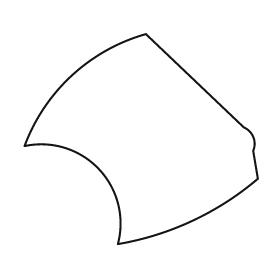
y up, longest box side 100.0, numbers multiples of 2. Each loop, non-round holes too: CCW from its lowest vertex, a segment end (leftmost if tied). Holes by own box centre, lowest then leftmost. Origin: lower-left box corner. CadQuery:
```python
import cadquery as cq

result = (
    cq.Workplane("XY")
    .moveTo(40.0, 0.0)
    .threePointArc((72.0, 10.0), (100.0, 28.0))
    .lineTo(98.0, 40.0)
    .threePointArc((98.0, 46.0), (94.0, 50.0))
    .lineTo(52.0, 90.0)
    .threePointArc((20.0, 72.0), (0.0, 42.0))
    .threePointArc((32.0, 32.0), (40.0, 0.0))
    .close()
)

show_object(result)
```